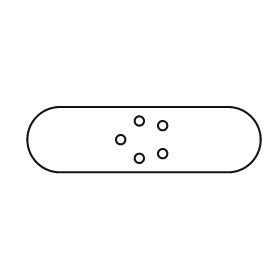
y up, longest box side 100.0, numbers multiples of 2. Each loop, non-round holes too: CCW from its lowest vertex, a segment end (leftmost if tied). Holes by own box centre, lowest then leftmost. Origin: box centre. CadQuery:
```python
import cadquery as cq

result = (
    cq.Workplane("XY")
    .moveTo(-36.0, -14.0)
    .lineTo(36.0, -14.0)
    .threePointArc((50.0, 0.0), (36.0, 14.0))
    .lineTo(-36.0, 14.0)
    .threePointArc((-50.0, 0.0), (-36.0, -14.0))
    .close()
    .moveTo(-2.0, -8.0)
    .circle(2.0)
    .moveTo(8.0, -6.0)
    .circle(2.0)
    .moveTo(-10.0, 0.0)
    .circle(2.0)
    .moveTo(8.0, 6.0)
    .circle(2.0)
    .moveTo(-2.0, 8.0)
    .circle(2.0)
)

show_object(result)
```